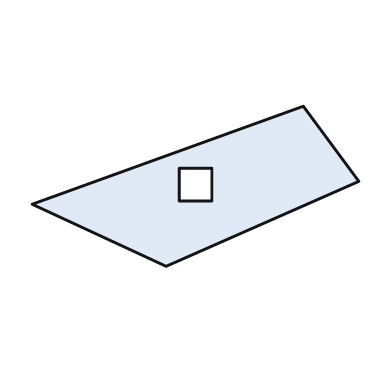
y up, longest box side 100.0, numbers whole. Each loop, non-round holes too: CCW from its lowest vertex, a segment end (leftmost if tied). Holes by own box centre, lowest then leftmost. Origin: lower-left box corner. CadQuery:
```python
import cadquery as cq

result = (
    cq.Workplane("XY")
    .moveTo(41.0, 0.0)
    .lineTo(100.0, 26.0)
    .lineTo(83.0, 49.0)
    .lineTo(0.0, 19.0)
    .close()
    .moveTo(45.0, 20.0)
    .lineTo(55.0, 20.0)
    .lineTo(55.0, 30.0)
    .lineTo(45.0, 30.0)
    .close()
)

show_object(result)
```